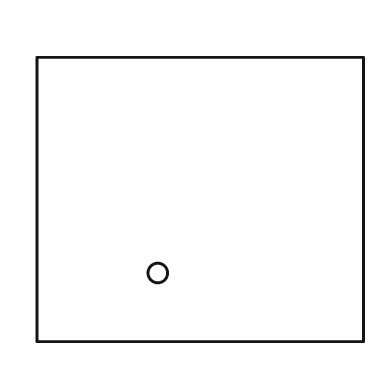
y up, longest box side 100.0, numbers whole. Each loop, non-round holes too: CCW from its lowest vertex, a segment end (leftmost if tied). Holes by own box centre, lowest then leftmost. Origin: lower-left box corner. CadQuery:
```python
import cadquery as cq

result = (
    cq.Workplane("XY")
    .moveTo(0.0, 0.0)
    .lineTo(100.0, 0.0)
    .lineTo(100.0, 87.0)
    .lineTo(0.0, 87.0)
    .close()
    .moveTo(37.0, 21.0)
    .circle(3.0)
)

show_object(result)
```